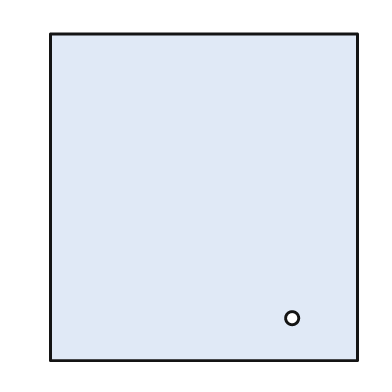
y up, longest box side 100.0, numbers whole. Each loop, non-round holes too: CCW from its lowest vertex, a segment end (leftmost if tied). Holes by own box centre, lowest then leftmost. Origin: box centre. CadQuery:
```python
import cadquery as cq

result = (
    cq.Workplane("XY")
    .moveTo(-47.0, -50.0)
    .lineTo(47.0, -50.0)
    .lineTo(47.0, 50.0)
    .lineTo(-47.0, 50.0)
    .close()
    .moveTo(27.0, -37.0)
    .circle(2.0)
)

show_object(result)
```